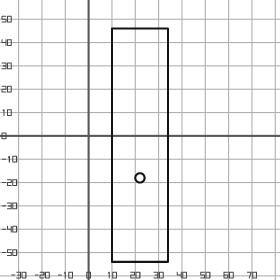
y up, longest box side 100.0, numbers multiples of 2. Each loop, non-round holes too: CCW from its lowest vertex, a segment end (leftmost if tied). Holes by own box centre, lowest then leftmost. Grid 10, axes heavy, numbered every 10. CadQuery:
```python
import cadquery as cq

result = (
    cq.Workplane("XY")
    .moveTo(10.0, -54.0)
    .lineTo(34.0, -54.0)
    .lineTo(34.0, 46.0)
    .lineTo(10.0, 46.0)
    .close()
    .moveTo(22.0, -18.0)
    .circle(2.0)
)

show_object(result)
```